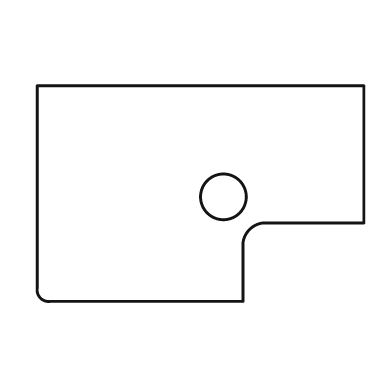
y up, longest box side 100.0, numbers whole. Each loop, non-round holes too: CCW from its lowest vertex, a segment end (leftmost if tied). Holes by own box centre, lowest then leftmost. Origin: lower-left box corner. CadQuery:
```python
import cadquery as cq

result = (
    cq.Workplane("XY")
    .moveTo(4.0, 0.0)
    .lineTo(63.0, 0.0)
    .lineTo(63.0, 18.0)
    .threePointArc((65.0, 22.0), (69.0, 24.0))
    .lineTo(100.0, 24.0)
    .lineTo(100.0, 66.0)
    .lineTo(0.0, 66.0)
    .lineTo(0.0, 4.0)
    .threePointArc((1.0, 1.0), (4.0, 0.0))
    .close()
    .moveTo(57.0, 32.0)
    .circle(7.0)
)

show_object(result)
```